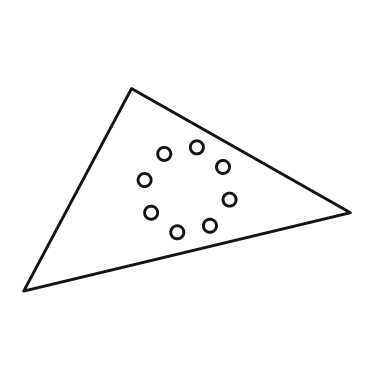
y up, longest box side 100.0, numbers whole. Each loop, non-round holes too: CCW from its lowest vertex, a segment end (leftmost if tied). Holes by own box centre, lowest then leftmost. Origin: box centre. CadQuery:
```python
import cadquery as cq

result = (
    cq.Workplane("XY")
    .moveTo(-50.0, -31.0)
    .lineTo(50.0, -7.0)
    .lineTo(-17.0, 31.0)
    .close()
    .moveTo(-3.0, -13.0)
    .circle(2.0)
    .moveTo(7.0, -11.0)
    .circle(2.0)
    .moveTo(-11.0, -7.0)
    .circle(2.0)
    .moveTo(13.0, -3.0)
    .circle(2.0)
    .moveTo(-13.0, 3.0)
    .circle(2.0)
    .moveTo(11.0, 7.0)
    .circle(2.0)
    .moveTo(-7.0, 11.0)
    .circle(2.0)
    .moveTo(3.0, 13.0)
    .circle(2.0)
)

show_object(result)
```